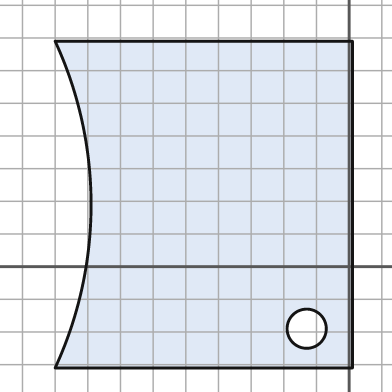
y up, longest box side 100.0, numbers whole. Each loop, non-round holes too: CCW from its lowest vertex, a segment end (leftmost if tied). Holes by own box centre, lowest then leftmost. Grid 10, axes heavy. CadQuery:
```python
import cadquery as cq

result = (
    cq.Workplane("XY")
    .moveTo(-90.0, -31.0)
    .lineTo(1.0, -31.0)
    .lineTo(1.0, 69.0)
    .lineTo(-90.0, 69.0)
    .threePointArc((-79.0, 19.0), (-90.0, -31.0))
    .close()
    .moveTo(-13.0, -19.0)
    .circle(6.0)
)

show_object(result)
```